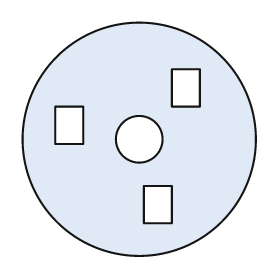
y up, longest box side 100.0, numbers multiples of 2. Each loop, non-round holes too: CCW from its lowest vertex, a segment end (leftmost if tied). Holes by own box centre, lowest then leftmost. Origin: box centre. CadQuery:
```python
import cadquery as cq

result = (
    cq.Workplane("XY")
    .moveTo(0.0, 0.0)
    .circle(50.0)
    .moveTo(2.0, -36.0)
    .lineTo(14.0, -36.0)
    .lineTo(14.0, -20.0)
    .lineTo(2.0, -20.0)
    .close()
    .moveTo(0.0, 0.0)
    .circle(10.0)
    .moveTo(-36.0, -2.0)
    .lineTo(-24.0, -2.0)
    .lineTo(-24.0, 14.0)
    .lineTo(-36.0, 14.0)
    .close()
    .moveTo(14.0, 14.0)
    .lineTo(26.0, 14.0)
    .lineTo(26.0, 30.0)
    .lineTo(14.0, 30.0)
    .close()
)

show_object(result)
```